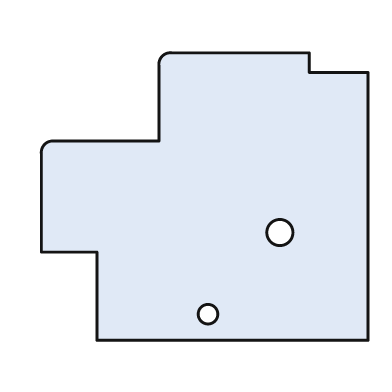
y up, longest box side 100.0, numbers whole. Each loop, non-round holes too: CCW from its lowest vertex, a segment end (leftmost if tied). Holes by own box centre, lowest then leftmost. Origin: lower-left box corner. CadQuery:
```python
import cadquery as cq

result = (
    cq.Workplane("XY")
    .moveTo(17.0, 0.0)
    .lineTo(100.0, 0.0)
    .lineTo(100.0, 82.0)
    .lineTo(82.0, 82.0)
    .lineTo(82.0, 88.0)
    .lineTo(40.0, 88.0)
    .threePointArc((37.0, 87.0), (36.0, 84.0))
    .lineTo(36.0, 61.0)
    .lineTo(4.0, 61.0)
    .threePointArc((1.0, 60.0), (0.0, 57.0))
    .lineTo(0.0, 27.0)
    .lineTo(17.0, 27.0)
    .close()
    .moveTo(51.0, 8.0)
    .circle(3.0)
    .moveTo(73.0, 33.0)
    .circle(4.0)
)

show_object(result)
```